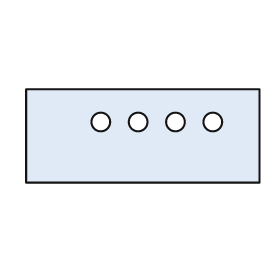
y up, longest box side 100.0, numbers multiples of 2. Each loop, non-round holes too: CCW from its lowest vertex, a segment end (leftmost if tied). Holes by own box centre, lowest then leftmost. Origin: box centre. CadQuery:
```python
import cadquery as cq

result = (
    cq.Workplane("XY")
    .moveTo(-50.0, -20.0)
    .lineTo(50.0, -20.0)
    .lineTo(50.0, 20.0)
    .lineTo(-50.0, 20.0)
    .close()
    .moveTo(-18.0, 6.0)
    .circle(4.0)
    .moveTo(-2.0, 6.0)
    .circle(4.0)
    .moveTo(14.0, 6.0)
    .circle(4.0)
    .moveTo(30.0, 6.0)
    .circle(4.0)
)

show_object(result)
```